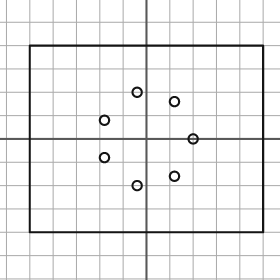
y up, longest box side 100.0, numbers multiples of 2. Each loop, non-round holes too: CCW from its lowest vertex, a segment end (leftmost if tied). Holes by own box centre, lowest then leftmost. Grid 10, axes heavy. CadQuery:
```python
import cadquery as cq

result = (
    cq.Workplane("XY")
    .moveTo(-50.0, -40.0)
    .lineTo(50.0, -40.0)
    .lineTo(50.0, 40.0)
    .lineTo(-50.0, 40.0)
    .close()
    .moveTo(-4.0, -20.0)
    .circle(2.0)
    .moveTo(12.0, -16.0)
    .circle(2.0)
    .moveTo(-18.0, -8.0)
    .circle(2.0)
    .moveTo(20.0, 0.0)
    .circle(2.0)
    .moveTo(-18.0, 8.0)
    .circle(2.0)
    .moveTo(12.0, 16.0)
    .circle(2.0)
    .moveTo(-4.0, 20.0)
    .circle(2.0)
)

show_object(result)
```